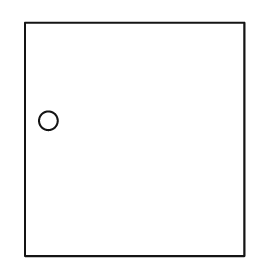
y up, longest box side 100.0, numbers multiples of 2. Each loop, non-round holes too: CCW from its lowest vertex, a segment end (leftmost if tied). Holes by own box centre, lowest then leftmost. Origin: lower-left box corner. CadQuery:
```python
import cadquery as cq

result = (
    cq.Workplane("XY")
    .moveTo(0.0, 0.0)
    .lineTo(94.0, 0.0)
    .lineTo(94.0, 100.0)
    .lineTo(0.0, 100.0)
    .close()
    .moveTo(10.0, 58.0)
    .circle(4.0)
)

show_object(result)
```